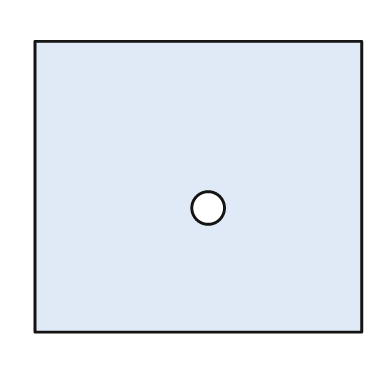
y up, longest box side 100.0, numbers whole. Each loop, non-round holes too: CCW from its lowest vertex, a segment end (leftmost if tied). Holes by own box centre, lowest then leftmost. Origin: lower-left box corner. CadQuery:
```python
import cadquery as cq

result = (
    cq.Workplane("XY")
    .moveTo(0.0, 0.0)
    .lineTo(100.0, 0.0)
    .lineTo(100.0, 89.0)
    .lineTo(0.0, 89.0)
    .close()
    .moveTo(53.0, 38.0)
    .circle(5.0)
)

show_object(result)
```